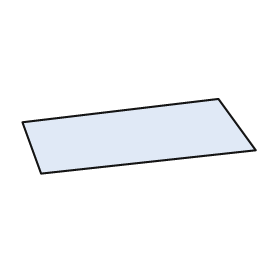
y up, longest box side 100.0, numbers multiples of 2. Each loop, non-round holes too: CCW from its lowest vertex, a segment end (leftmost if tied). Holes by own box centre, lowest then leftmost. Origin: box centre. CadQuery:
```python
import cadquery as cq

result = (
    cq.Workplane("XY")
    .moveTo(-42.0, -16.0)
    .lineTo(50.0, -6.0)
    .lineTo(34.0, 16.0)
    .lineTo(-50.0, 6.0)
    .close()
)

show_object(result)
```